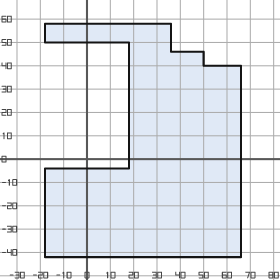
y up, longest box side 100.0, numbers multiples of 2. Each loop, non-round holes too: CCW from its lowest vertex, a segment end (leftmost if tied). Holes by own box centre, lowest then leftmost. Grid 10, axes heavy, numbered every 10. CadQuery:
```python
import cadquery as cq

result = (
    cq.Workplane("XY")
    .moveTo(-18.0, -42.0)
    .lineTo(66.0, -42.0)
    .lineTo(66.0, 40.0)
    .lineTo(50.0, 40.0)
    .lineTo(50.0, 46.0)
    .lineTo(36.0, 46.0)
    .lineTo(36.0, 58.0)
    .lineTo(-18.0, 58.0)
    .lineTo(-18.0, 50.0)
    .lineTo(18.0, 50.0)
    .lineTo(18.0, -4.0)
    .lineTo(-18.0, -4.0)
    .close()
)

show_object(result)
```